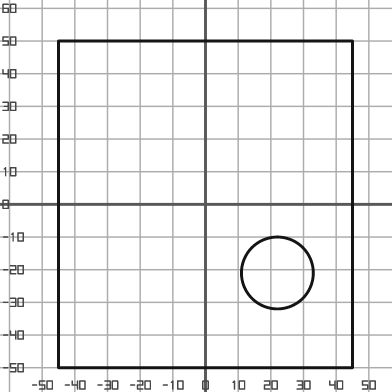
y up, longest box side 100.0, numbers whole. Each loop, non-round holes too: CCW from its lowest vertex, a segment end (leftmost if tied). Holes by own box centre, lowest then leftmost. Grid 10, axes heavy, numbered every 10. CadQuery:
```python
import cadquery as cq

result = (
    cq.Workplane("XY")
    .moveTo(-45.0, -50.0)
    .lineTo(45.0, -50.0)
    .lineTo(45.0, 50.0)
    .lineTo(-45.0, 50.0)
    .close()
    .moveTo(22.0, -21.0)
    .circle(11.0)
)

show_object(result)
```